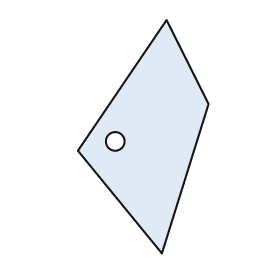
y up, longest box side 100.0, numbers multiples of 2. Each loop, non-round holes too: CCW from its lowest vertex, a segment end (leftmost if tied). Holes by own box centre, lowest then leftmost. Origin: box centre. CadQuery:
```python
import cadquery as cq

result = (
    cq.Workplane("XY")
    .moveTo(8.0, -50.0)
    .lineTo(28.0, 14.0)
    .lineTo(10.0, 50.0)
    .lineTo(-28.0, -6.0)
    .close()
    .moveTo(-12.0, -2.0)
    .circle(4.0)
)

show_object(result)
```